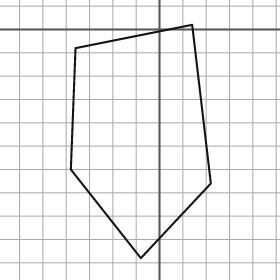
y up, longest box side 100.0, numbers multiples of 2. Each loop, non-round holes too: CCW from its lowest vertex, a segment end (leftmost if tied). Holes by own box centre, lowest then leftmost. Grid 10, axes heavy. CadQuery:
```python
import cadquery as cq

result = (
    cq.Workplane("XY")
    .moveTo(-8.0, -98.0)
    .lineTo(22.0, -66.0)
    .lineTo(14.0, 2.0)
    .lineTo(-36.0, -8.0)
    .lineTo(-38.0, -60.0)
    .close()
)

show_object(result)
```